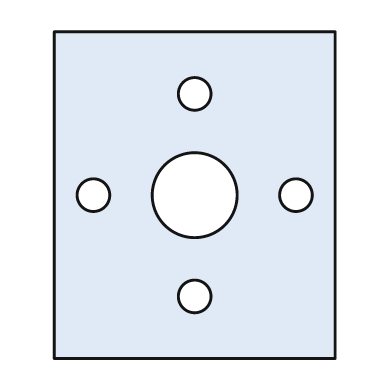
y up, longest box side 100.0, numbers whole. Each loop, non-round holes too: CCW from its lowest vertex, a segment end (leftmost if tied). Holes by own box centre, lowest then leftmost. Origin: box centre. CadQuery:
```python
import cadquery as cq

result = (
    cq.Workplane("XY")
    .moveTo(-43.0, -50.0)
    .lineTo(43.0, -50.0)
    .lineTo(43.0, 50.0)
    .lineTo(-43.0, 50.0)
    .close()
    .moveTo(0.0, -31.0)
    .circle(5.0)
    .moveTo(-31.0, 0.0)
    .circle(5.0)
    .moveTo(0.0, 0.0)
    .circle(13.0)
    .moveTo(31.0, 0.0)
    .circle(5.0)
    .moveTo(0.0, 31.0)
    .circle(5.0)
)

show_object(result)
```